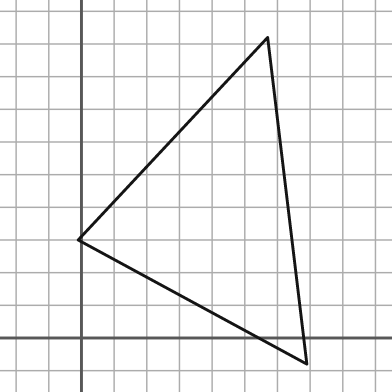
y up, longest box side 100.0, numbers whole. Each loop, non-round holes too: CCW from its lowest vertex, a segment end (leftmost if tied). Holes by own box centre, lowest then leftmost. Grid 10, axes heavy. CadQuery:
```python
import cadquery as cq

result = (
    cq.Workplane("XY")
    .moveTo(69.0, -8.0)
    .lineTo(57.0, 92.0)
    .lineTo(-1.0, 30.0)
    .close()
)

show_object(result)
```